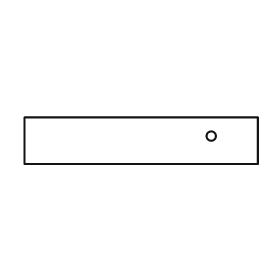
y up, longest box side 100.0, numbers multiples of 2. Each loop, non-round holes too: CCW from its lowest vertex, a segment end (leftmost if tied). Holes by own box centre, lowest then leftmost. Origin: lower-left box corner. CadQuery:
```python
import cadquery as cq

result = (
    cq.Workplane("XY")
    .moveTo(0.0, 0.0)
    .lineTo(100.0, 0.0)
    .lineTo(100.0, 20.0)
    .lineTo(0.0, 20.0)
    .close()
    .moveTo(80.0, 12.0)
    .circle(2.0)
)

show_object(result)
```